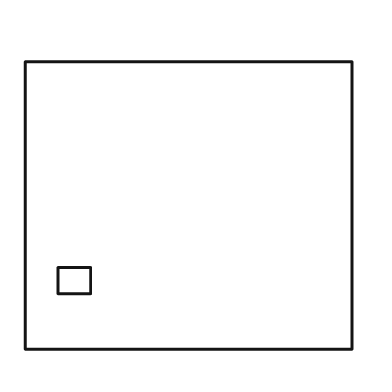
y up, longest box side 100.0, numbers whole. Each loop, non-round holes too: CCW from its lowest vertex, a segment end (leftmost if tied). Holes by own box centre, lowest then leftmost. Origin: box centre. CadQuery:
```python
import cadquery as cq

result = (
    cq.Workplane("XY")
    .moveTo(-50.0, -44.0)
    .lineTo(50.0, -44.0)
    .lineTo(50.0, 44.0)
    .lineTo(-50.0, 44.0)
    .close()
    .moveTo(-40.0, -27.0)
    .lineTo(-30.0, -27.0)
    .lineTo(-30.0, -19.0)
    .lineTo(-40.0, -19.0)
    .close()
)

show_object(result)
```